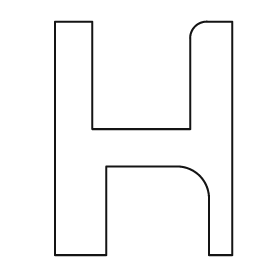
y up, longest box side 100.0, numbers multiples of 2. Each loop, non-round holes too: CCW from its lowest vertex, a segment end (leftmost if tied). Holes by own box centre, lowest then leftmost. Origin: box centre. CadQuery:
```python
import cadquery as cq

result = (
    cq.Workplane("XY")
    .moveTo(-38.0, -50.0)
    .lineTo(-16.0, -50.0)
    .lineTo(-16.0, -12.0)
    .lineTo(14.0, -12.0)
    .threePointArc((24.0, -16.0), (28.0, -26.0))
    .lineTo(28.0, -50.0)
    .lineTo(38.0, -50.0)
    .lineTo(38.0, 50.0)
    .lineTo(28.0, 50.0)
    .threePointArc((22.0, 48.0), (20.0, 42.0))
    .lineTo(20.0, 4.0)
    .lineTo(-22.0, 4.0)
    .lineTo(-22.0, 50.0)
    .lineTo(-38.0, 50.0)
    .close()
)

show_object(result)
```